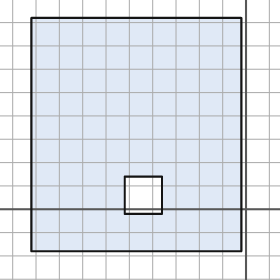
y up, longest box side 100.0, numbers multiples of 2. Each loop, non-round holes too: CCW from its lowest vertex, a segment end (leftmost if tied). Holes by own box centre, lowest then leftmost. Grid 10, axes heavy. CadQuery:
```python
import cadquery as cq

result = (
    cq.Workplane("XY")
    .moveTo(-92.0, -18.0)
    .lineTo(-2.0, -18.0)
    .lineTo(-2.0, 82.0)
    .lineTo(-92.0, 82.0)
    .close()
    .moveTo(-52.0, -2.0)
    .lineTo(-36.0, -2.0)
    .lineTo(-36.0, 14.0)
    .lineTo(-52.0, 14.0)
    .close()
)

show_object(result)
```